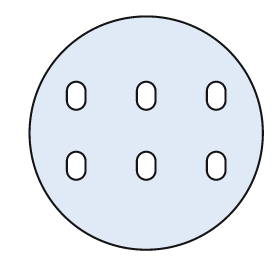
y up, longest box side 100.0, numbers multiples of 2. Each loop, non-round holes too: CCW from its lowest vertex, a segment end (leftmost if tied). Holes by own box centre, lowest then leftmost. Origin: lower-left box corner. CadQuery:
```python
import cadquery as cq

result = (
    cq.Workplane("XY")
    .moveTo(50.0, 50.0)
    .circle(50.0)
    .moveTo(16.0, 34.0)
    .threePointArc((20.0, 30.0), (24.0, 34.0))
    .lineTo(24.0, 38.0)
    .threePointArc((20.0, 42.0), (16.0, 38.0))
    .close()
    .moveTo(46.0, 34.0)
    .threePointArc((50.0, 30.0), (54.0, 34.0))
    .lineTo(54.0, 38.0)
    .threePointArc((50.0, 42.0), (46.0, 38.0))
    .close()
    .moveTo(76.0, 34.0)
    .threePointArc((80.0, 30.0), (84.0, 34.0))
    .lineTo(84.0, 38.0)
    .threePointArc((80.0, 42.0), (76.0, 38.0))
    .close()
    .moveTo(16.0, 64.0)
    .threePointArc((20.0, 60.0), (24.0, 64.0))
    .lineTo(24.0, 68.0)
    .threePointArc((20.0, 72.0), (16.0, 68.0))
    .close()
    .moveTo(46.0, 64.0)
    .threePointArc((50.0, 60.0), (54.0, 64.0))
    .lineTo(54.0, 68.0)
    .threePointArc((50.0, 72.0), (46.0, 68.0))
    .close()
    .moveTo(76.0, 64.0)
    .threePointArc((80.0, 60.0), (84.0, 64.0))
    .lineTo(84.0, 68.0)
    .threePointArc((80.0, 72.0), (76.0, 68.0))
    .close()
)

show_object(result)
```